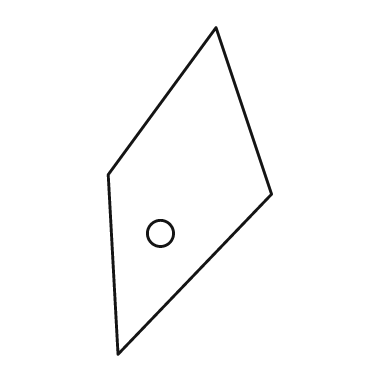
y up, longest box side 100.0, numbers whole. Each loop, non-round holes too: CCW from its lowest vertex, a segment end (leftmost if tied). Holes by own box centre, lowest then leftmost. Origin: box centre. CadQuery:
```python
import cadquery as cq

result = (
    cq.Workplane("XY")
    .moveTo(-22.0, -50.0)
    .lineTo(25.0, -1.0)
    .lineTo(8.0, 50.0)
    .lineTo(-25.0, 5.0)
    .close()
    .moveTo(-9.0, -13.0)
    .circle(4.0)
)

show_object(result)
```